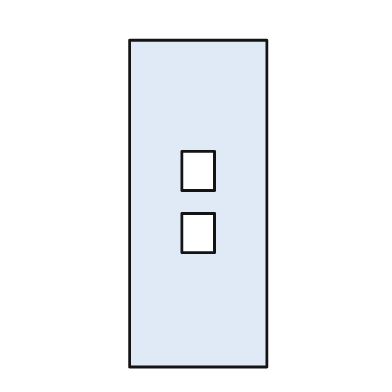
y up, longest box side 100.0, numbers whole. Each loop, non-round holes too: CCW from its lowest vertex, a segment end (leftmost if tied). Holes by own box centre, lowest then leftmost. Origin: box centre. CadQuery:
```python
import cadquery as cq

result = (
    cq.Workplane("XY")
    .moveTo(-21.0, -50.0)
    .lineTo(21.0, -50.0)
    .lineTo(21.0, 50.0)
    .lineTo(-21.0, 50.0)
    .close()
    .moveTo(-5.0, -15.0)
    .lineTo(5.0, -15.0)
    .lineTo(5.0, -3.0)
    .lineTo(-5.0, -3.0)
    .close()
    .moveTo(-5.0, 4.0)
    .lineTo(5.0, 4.0)
    .lineTo(5.0, 16.0)
    .lineTo(-5.0, 16.0)
    .close()
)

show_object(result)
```